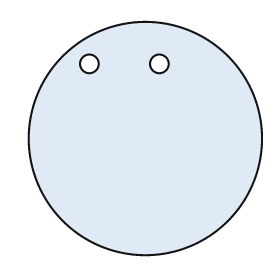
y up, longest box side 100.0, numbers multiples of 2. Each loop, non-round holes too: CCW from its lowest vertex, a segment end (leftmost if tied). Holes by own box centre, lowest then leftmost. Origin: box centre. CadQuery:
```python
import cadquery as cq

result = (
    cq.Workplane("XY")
    .moveTo(0.0, 0.0)
    .circle(50.0)
    .moveTo(-24.0, 32.0)
    .circle(4.0)
    .moveTo(6.0, 32.0)
    .circle(4.0)
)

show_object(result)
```